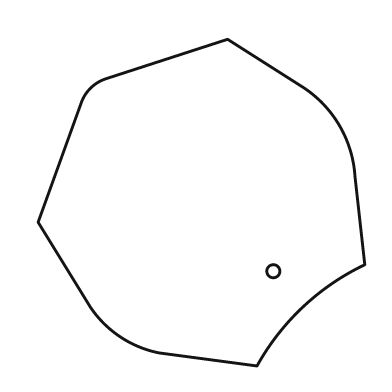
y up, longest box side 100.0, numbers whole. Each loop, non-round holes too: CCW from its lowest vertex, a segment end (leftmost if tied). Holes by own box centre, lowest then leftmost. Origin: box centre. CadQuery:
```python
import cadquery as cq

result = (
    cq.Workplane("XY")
    .moveTo(17.0, -50.0)
    .threePointArc((31.0, -32.0), (50.0, -19.0))
    .lineTo(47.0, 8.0)
    .threePointArc((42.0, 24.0), (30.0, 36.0))
    .lineTo(8.0, 50.0)
    .lineTo(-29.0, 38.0)
    .threePointArc((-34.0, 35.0), (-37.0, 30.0))
    .lineTo(-50.0, -6.0)
    .lineTo(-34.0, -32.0)
    .threePointArc((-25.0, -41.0), (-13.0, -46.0))
    .close()
    .moveTo(22.0, -21.0)
    .circle(2.0)
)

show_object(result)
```